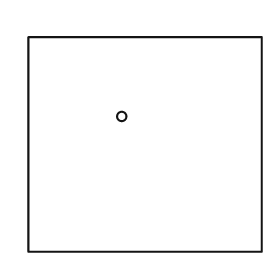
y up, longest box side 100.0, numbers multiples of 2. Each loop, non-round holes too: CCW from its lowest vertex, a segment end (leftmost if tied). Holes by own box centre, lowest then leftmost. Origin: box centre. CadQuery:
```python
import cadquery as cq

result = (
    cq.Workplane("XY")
    .moveTo(-50.0, -46.0)
    .lineTo(50.0, -46.0)
    .lineTo(50.0, 46.0)
    .lineTo(-50.0, 46.0)
    .close()
    .moveTo(-10.0, 12.0)
    .circle(2.0)
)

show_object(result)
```